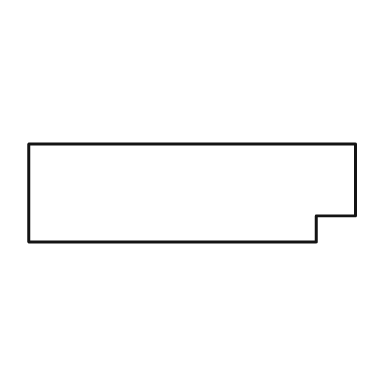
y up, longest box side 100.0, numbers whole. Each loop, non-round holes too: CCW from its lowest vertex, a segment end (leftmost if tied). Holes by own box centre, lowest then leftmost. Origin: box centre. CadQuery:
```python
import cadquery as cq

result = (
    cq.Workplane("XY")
    .moveTo(-50.0, -15.0)
    .lineTo(38.0, -15.0)
    .lineTo(38.0, -7.0)
    .lineTo(50.0, -7.0)
    .lineTo(50.0, 15.0)
    .lineTo(-50.0, 15.0)
    .close()
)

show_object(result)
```